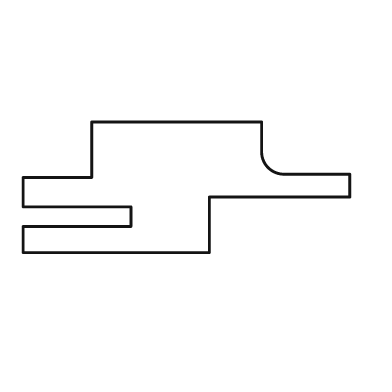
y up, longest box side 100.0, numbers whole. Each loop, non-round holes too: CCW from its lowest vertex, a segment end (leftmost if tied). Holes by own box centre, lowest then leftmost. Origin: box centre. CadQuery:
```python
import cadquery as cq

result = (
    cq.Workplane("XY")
    .moveTo(-50.0, -20.0)
    .lineTo(7.0, -20.0)
    .lineTo(7.0, -3.0)
    .lineTo(50.0, -3.0)
    .lineTo(50.0, 4.0)
    .lineTo(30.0, 4.0)
    .threePointArc((25.0, 6.0), (23.0, 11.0))
    .lineTo(23.0, 20.0)
    .lineTo(-29.0, 20.0)
    .lineTo(-29.0, 3.0)
    .lineTo(-50.0, 3.0)
    .lineTo(-50.0, -6.0)
    .lineTo(-17.0, -6.0)
    .lineTo(-17.0, -12.0)
    .lineTo(-50.0, -12.0)
    .close()
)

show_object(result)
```